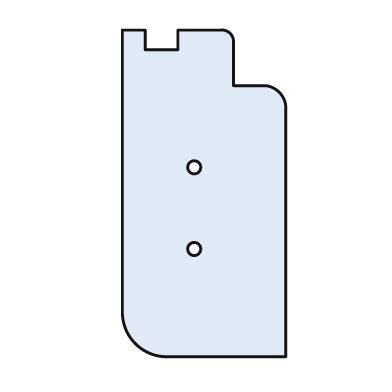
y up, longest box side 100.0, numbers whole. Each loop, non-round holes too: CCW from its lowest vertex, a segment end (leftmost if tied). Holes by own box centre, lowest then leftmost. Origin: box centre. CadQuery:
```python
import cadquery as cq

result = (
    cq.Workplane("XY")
    .moveTo(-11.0, -50.0)
    .lineTo(25.0, -50.0)
    .lineTo(25.0, 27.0)
    .threePointArc((23.0, 31.0), (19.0, 33.0))
    .lineTo(9.0, 33.0)
    .lineTo(9.0, 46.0)
    .threePointArc((8.0, 49.0), (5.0, 50.0))
    .lineTo(-8.0, 50.0)
    .lineTo(-8.0, 44.0)
    .lineTo(-18.0, 44.0)
    .lineTo(-18.0, 50.0)
    .lineTo(-25.0, 50.0)
    .lineTo(-25.0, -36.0)
    .threePointArc((-21.0, -46.0), (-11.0, -50.0))
    .close()
    .moveTo(-3.0, -17.0)
    .circle(2.0)
    .moveTo(-3.0, 8.0)
    .circle(2.0)
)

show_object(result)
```